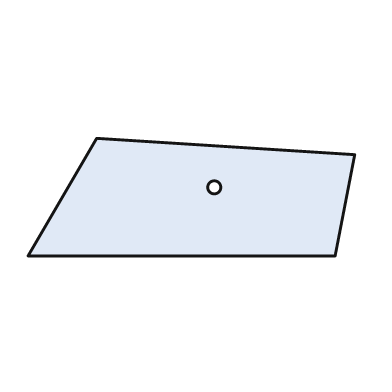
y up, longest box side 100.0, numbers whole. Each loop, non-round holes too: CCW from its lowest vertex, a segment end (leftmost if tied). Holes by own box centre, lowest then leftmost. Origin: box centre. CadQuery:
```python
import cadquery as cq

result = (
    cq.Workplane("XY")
    .moveTo(-50.0, -18.0)
    .lineTo(44.0, -18.0)
    .lineTo(50.0, 13.0)
    .lineTo(-29.0, 18.0)
    .close()
    .moveTo(7.0, 3.0)
    .circle(2.0)
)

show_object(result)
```